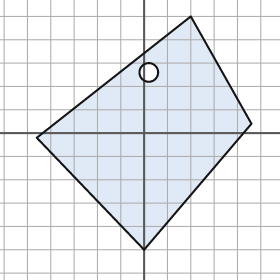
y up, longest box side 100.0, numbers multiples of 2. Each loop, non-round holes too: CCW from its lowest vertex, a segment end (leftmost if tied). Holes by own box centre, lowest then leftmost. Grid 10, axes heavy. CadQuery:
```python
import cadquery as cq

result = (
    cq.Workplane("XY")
    .moveTo(0.0, -50.0)
    .lineTo(46.0, 4.0)
    .lineTo(20.0, 50.0)
    .lineTo(-46.0, -2.0)
    .close()
    .moveTo(2.0, 26.0)
    .circle(4.0)
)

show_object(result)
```